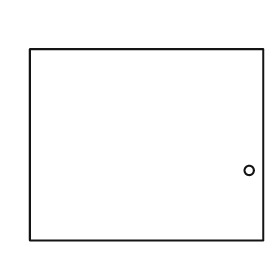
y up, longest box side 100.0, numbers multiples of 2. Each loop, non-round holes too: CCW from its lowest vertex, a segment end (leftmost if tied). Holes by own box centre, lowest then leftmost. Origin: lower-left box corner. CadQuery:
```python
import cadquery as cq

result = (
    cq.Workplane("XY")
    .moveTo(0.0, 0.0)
    .lineTo(100.0, 0.0)
    .lineTo(100.0, 82.0)
    .lineTo(0.0, 82.0)
    .close()
    .moveTo(94.0, 30.0)
    .circle(2.0)
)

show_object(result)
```